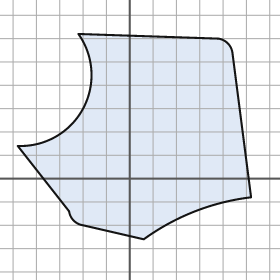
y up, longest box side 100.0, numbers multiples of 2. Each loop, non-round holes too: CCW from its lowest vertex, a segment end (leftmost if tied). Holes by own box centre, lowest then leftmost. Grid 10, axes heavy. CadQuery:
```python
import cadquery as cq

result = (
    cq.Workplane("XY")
    .moveTo(6.0, -26.0)
    .threePointArc((28.0, -14.0), (52.0, -8.0))
    .lineTo(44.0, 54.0)
    .threePointArc((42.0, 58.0), (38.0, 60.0))
    .lineTo(-22.0, 62.0)
    .threePointArc((-20.0, 30.0), (-48.0, 14.0))
    .lineTo(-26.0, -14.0)
    .threePointArc((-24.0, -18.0), (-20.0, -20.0))
    .close()
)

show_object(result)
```